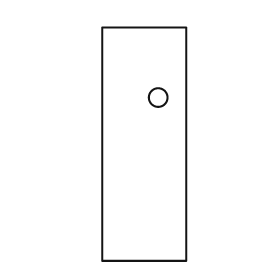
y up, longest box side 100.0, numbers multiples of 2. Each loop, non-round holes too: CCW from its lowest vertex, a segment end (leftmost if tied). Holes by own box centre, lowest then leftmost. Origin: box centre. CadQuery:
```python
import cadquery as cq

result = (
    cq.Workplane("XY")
    .moveTo(-18.0, -50.0)
    .lineTo(18.0, -50.0)
    .lineTo(18.0, 50.0)
    .lineTo(-18.0, 50.0)
    .close()
    .moveTo(6.0, 20.0)
    .circle(4.0)
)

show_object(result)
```